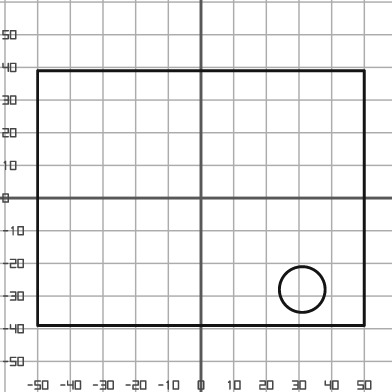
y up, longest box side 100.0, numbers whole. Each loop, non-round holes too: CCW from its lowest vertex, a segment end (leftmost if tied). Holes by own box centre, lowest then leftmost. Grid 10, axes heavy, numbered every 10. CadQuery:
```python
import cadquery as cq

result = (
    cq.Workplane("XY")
    .moveTo(-50.0, -39.0)
    .lineTo(50.0, -39.0)
    .lineTo(50.0, 39.0)
    .lineTo(-50.0, 39.0)
    .close()
    .moveTo(31.0, -28.0)
    .circle(7.0)
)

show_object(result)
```